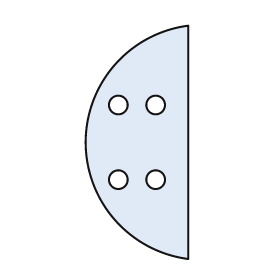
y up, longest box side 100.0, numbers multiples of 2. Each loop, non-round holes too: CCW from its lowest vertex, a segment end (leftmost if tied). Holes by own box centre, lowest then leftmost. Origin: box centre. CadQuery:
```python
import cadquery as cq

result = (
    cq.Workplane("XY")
    .moveTo(22.0, -50.0)
    .lineTo(22.0, 50.0)
    .threePointArc((-22.0, 0.0), (22.0, -50.0))
    .close()
    .moveTo(-8.0, -16.0)
    .circle(4.0)
    .moveTo(8.0, -16.0)
    .circle(4.0)
    .moveTo(-8.0, 16.0)
    .circle(4.0)
    .moveTo(8.0, 16.0)
    .circle(4.0)
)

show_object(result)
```